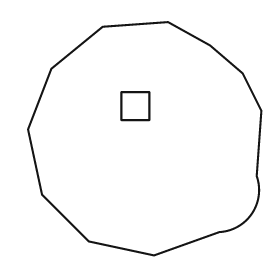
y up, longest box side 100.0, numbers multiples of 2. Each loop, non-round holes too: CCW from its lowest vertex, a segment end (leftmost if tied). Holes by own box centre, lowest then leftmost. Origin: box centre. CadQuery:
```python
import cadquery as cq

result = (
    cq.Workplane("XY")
    .moveTo(4.0, -50.0)
    .lineTo(32.0, -40.0)
    .threePointArc((46.0, -32.0), (48.0, -16.0))
    .lineTo(50.0, 12.0)
    .lineTo(42.0, 28.0)
    .lineTo(28.0, 40.0)
    .lineTo(10.0, 50.0)
    .lineTo(-18.0, 48.0)
    .lineTo(-40.0, 30.0)
    .lineTo(-50.0, 4.0)
    .lineTo(-44.0, -24.0)
    .lineTo(-24.0, -44.0)
    .close()
    .moveTo(-10.0, 8.0)
    .lineTo(2.0, 8.0)
    .lineTo(2.0, 20.0)
    .lineTo(-10.0, 20.0)
    .close()
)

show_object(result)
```